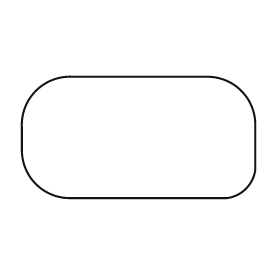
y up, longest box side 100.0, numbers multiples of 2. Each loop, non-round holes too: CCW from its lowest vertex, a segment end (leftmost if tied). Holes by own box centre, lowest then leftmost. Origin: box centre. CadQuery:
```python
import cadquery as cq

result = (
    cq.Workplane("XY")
    .moveTo(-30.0, -26.0)
    .lineTo(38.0, -26.0)
    .threePointArc((46.0, -22.0), (50.0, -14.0))
    .lineTo(50.0, 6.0)
    .threePointArc((44.0, 20.0), (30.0, 26.0))
    .lineTo(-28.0, 26.0)
    .threePointArc((-44.0, 20.0), (-50.0, 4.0))
    .lineTo(-50.0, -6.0)
    .threePointArc((-44.0, -20.0), (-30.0, -26.0))
    .close()
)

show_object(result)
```